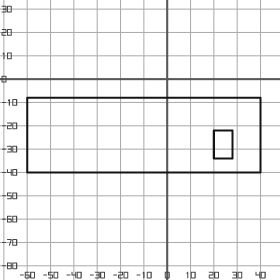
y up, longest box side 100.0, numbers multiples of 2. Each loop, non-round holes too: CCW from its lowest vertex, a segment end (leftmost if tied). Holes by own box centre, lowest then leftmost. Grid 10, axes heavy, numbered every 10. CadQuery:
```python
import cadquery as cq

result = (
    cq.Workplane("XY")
    .moveTo(-60.0, -40.0)
    .lineTo(40.0, -40.0)
    .lineTo(40.0, -8.0)
    .lineTo(-60.0, -8.0)
    .close()
    .moveTo(20.0, -34.0)
    .lineTo(28.0, -34.0)
    .lineTo(28.0, -22.0)
    .lineTo(20.0, -22.0)
    .close()
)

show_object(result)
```